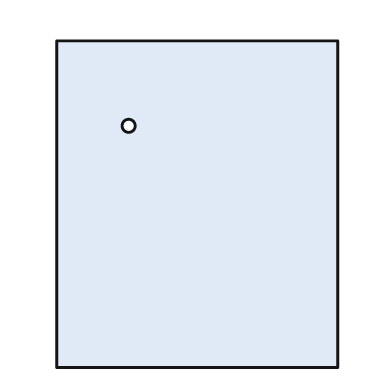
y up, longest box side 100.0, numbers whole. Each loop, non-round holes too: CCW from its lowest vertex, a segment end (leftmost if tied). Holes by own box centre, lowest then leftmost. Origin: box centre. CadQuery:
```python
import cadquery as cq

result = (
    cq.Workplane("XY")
    .moveTo(-43.0, -50.0)
    .lineTo(43.0, -50.0)
    .lineTo(43.0, 50.0)
    .lineTo(-43.0, 50.0)
    .close()
    .moveTo(-21.0, 24.0)
    .circle(2.0)
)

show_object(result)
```